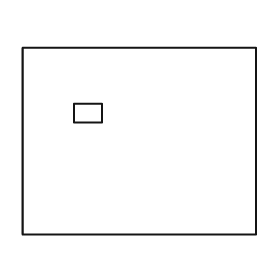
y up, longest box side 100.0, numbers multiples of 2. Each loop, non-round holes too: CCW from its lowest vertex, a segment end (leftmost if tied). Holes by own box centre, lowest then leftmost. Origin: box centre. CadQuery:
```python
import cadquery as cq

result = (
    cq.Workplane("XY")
    .moveTo(-50.0, -40.0)
    .lineTo(50.0, -40.0)
    .lineTo(50.0, 40.0)
    .lineTo(-50.0, 40.0)
    .close()
    .moveTo(-28.0, 8.0)
    .lineTo(-16.0, 8.0)
    .lineTo(-16.0, 16.0)
    .lineTo(-28.0, 16.0)
    .close()
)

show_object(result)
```